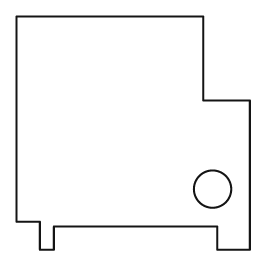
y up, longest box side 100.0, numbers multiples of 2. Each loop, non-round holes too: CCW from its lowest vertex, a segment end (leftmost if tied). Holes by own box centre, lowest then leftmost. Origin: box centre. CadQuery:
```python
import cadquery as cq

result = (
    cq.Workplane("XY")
    .moveTo(-40.0, -50.0)
    .lineTo(-34.0, -50.0)
    .lineTo(-34.0, -40.0)
    .lineTo(36.0, -40.0)
    .lineTo(36.0, -50.0)
    .lineTo(50.0, -50.0)
    .lineTo(50.0, 14.0)
    .lineTo(30.0, 14.0)
    .lineTo(30.0, 50.0)
    .lineTo(-50.0, 50.0)
    .lineTo(-50.0, -38.0)
    .lineTo(-40.0, -38.0)
    .close()
    .moveTo(34.0, -24.0)
    .circle(8.0)
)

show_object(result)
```